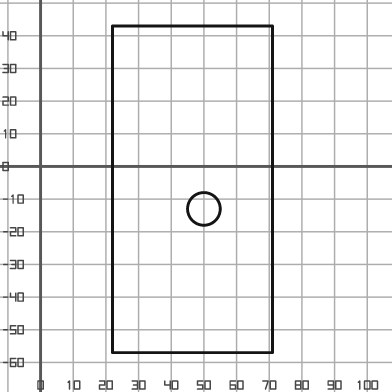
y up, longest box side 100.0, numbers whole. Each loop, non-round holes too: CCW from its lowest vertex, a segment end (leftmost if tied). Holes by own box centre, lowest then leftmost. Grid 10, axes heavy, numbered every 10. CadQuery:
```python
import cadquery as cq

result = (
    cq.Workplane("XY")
    .moveTo(22.0, -57.0)
    .lineTo(71.0, -57.0)
    .lineTo(71.0, 43.0)
    .lineTo(22.0, 43.0)
    .close()
    .moveTo(50.0, -13.0)
    .circle(5.0)
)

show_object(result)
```